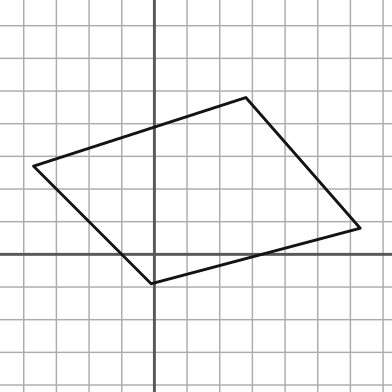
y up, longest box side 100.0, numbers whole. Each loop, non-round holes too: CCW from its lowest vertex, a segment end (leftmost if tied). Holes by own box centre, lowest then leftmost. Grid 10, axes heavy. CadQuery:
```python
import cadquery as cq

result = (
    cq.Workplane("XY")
    .moveTo(-1.0, -9.0)
    .lineTo(63.0, 8.0)
    .lineTo(28.0, 48.0)
    .lineTo(-37.0, 27.0)
    .close()
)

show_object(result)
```